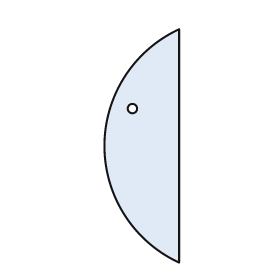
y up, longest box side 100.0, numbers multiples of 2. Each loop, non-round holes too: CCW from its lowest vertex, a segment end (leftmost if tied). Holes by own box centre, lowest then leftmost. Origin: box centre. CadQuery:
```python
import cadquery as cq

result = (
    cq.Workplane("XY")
    .moveTo(16.0, -50.0)
    .lineTo(16.0, 50.0)
    .threePointArc((-16.0, 0.0), (16.0, -50.0))
    .close()
    .moveTo(-4.0, 16.0)
    .circle(2.0)
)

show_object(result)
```